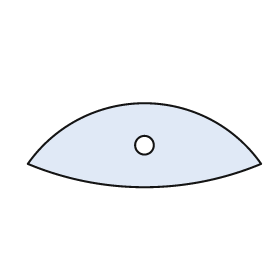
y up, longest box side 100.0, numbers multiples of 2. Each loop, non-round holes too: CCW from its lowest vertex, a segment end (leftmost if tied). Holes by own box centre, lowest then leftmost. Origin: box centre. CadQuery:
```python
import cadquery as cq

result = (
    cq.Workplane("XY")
    .moveTo(-50.0, -8.0)
    .threePointArc((0.0, -18.0), (50.0, -8.0))
    .threePointArc((0.0, 18.0), (-50.0, -8.0))
    .close()
    .moveTo(0.0, 0.0)
    .circle(4.0)
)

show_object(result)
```